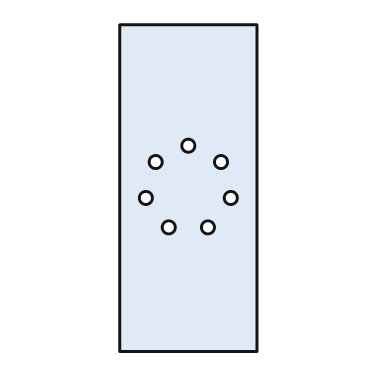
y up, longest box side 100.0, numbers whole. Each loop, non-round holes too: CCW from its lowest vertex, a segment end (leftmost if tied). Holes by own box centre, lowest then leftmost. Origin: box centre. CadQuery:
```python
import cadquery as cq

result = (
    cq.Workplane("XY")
    .moveTo(-21.0, -50.0)
    .lineTo(21.0, -50.0)
    .lineTo(21.0, 50.0)
    .lineTo(-21.0, 50.0)
    .close()
    .moveTo(-6.0, -12.0)
    .circle(2.0)
    .moveTo(6.0, -12.0)
    .circle(2.0)
    .moveTo(-13.0, -3.0)
    .circle(2.0)
    .moveTo(13.0, -3.0)
    .circle(2.0)
    .moveTo(-10.0, 8.0)
    .circle(2.0)
    .moveTo(10.0, 8.0)
    .circle(2.0)
    .moveTo(0.0, 13.0)
    .circle(2.0)
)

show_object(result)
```